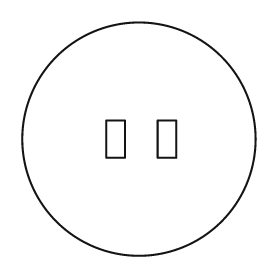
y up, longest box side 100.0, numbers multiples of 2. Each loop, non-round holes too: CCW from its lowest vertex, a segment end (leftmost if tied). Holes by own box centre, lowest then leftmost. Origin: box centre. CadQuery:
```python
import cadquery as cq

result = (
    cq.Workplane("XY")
    .moveTo(0.0, 0.0)
    .circle(50.0)
    .moveTo(-14.0, -8.0)
    .lineTo(-6.0, -8.0)
    .lineTo(-6.0, 8.0)
    .lineTo(-14.0, 8.0)
    .close()
    .moveTo(8.0, -8.0)
    .lineTo(16.0, -8.0)
    .lineTo(16.0, 8.0)
    .lineTo(8.0, 8.0)
    .close()
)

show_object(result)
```